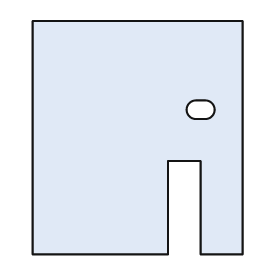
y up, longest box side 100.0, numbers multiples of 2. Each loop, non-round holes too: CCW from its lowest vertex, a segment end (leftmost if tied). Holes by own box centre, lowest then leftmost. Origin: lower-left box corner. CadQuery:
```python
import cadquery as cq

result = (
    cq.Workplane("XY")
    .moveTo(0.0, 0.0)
    .lineTo(58.0, 0.0)
    .lineTo(58.0, 40.0)
    .lineTo(72.0, 40.0)
    .lineTo(72.0, 0.0)
    .lineTo(90.0, 0.0)
    .lineTo(90.0, 100.0)
    .lineTo(0.0, 100.0)
    .close()
    .moveTo(70.0, 58.0)
    .lineTo(74.0, 58.0)
    .threePointArc((78.0, 62.0), (74.0, 66.0))
    .lineTo(70.0, 66.0)
    .threePointArc((66.0, 62.0), (70.0, 58.0))
    .close()
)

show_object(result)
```